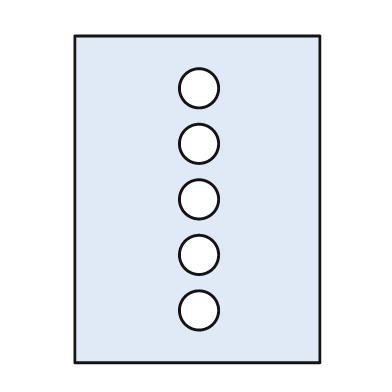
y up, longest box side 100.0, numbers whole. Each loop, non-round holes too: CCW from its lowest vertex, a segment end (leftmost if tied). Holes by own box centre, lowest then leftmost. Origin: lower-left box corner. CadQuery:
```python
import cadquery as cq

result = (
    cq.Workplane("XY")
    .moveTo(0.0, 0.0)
    .lineTo(75.0, 0.0)
    .lineTo(75.0, 100.0)
    .lineTo(0.0, 100.0)
    .close()
    .moveTo(38.0, 16.0)
    .circle(6.0)
    .moveTo(38.0, 33.0)
    .circle(6.0)
    .moveTo(38.0, 50.0)
    .circle(6.0)
    .moveTo(38.0, 67.0)
    .circle(6.0)
    .moveTo(38.0, 84.0)
    .circle(6.0)
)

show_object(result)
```